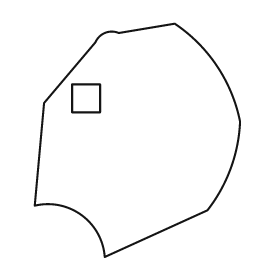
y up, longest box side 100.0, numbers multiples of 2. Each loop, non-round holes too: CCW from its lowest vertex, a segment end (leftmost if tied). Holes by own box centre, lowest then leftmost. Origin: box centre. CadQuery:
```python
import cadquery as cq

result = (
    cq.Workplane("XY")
    .moveTo(-14.0, -50.0)
    .lineTo(30.0, -30.0)
    .threePointArc((40.0, -12.0), (44.0, 8.0))
    .threePointArc((34.0, 32.0), (16.0, 50.0))
    .lineTo(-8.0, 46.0)
    .threePointArc((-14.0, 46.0), (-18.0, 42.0))
    .lineTo(-40.0, 16.0)
    .lineTo(-44.0, -28.0)
    .threePointArc((-24.0, -32.0), (-14.0, -50.0))
    .close()
    .moveTo(-28.0, 12.0)
    .lineTo(-16.0, 12.0)
    .lineTo(-16.0, 24.0)
    .lineTo(-28.0, 24.0)
    .close()
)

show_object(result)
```